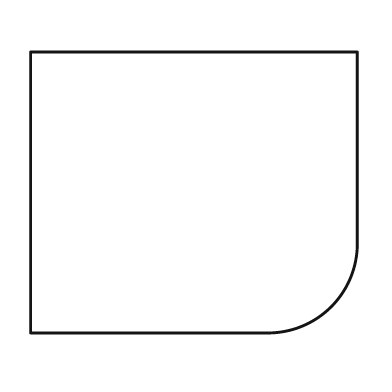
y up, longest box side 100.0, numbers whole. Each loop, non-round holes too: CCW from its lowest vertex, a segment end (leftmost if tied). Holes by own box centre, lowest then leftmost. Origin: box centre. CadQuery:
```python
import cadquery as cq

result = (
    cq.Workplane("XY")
    .moveTo(-50.0, -43.0)
    .lineTo(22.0, -43.0)
    .threePointArc((42.0, -35.0), (50.0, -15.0))
    .lineTo(50.0, 43.0)
    .lineTo(-50.0, 43.0)
    .close()
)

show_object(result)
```